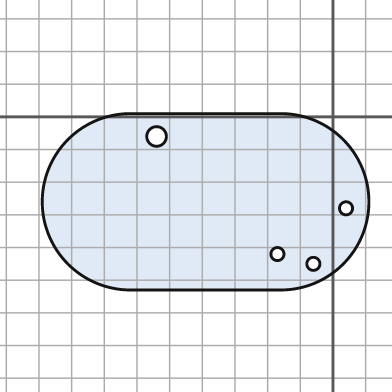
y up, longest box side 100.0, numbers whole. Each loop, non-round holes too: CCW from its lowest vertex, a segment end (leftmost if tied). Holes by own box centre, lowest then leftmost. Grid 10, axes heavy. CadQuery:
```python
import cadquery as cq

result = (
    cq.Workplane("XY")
    .moveTo(-62.0, -53.0)
    .lineTo(-16.0, -53.0)
    .threePointArc((11.0, -26.0), (-16.0, 1.0))
    .lineTo(-62.0, 1.0)
    .threePointArc((-89.0, -26.0), (-62.0, -53.0))
    .close()
    .moveTo(-6.0, -45.0)
    .circle(2.0)
    .moveTo(-17.0, -42.0)
    .circle(2.0)
    .moveTo(4.0, -28.0)
    .circle(2.0)
    .moveTo(-54.0, -6.0)
    .circle(3.0)
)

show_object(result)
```